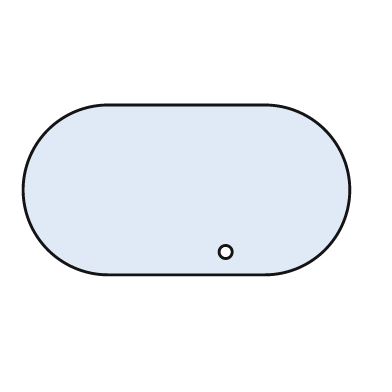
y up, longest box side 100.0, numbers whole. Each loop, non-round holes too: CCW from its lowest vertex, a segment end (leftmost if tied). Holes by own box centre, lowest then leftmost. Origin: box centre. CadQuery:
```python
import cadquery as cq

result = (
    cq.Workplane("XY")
    .moveTo(-24.0, -26.0)
    .lineTo(24.0, -26.0)
    .threePointArc((50.0, 0.0), (24.0, 26.0))
    .lineTo(-24.0, 26.0)
    .threePointArc((-50.0, 0.0), (-24.0, -26.0))
    .close()
    .moveTo(12.0, -19.0)
    .circle(2.0)
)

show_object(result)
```